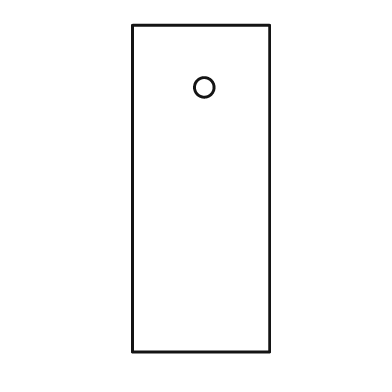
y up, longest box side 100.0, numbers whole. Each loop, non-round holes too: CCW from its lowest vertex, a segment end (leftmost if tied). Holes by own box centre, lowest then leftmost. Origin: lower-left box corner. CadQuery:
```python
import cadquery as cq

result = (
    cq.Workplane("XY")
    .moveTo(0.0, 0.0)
    .lineTo(42.0, 0.0)
    .lineTo(42.0, 100.0)
    .lineTo(0.0, 100.0)
    .close()
    .moveTo(22.0, 81.0)
    .circle(3.0)
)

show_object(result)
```